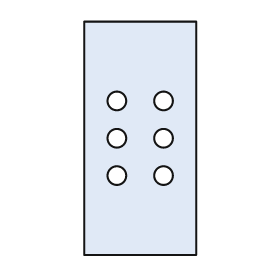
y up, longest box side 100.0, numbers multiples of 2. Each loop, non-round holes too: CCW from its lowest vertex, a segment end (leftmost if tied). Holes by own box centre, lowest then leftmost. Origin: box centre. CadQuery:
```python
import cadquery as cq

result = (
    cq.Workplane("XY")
    .moveTo(-24.0, -50.0)
    .lineTo(24.0, -50.0)
    .lineTo(24.0, 50.0)
    .lineTo(-24.0, 50.0)
    .close()
    .moveTo(-10.0, -16.0)
    .circle(4.0)
    .moveTo(10.0, -16.0)
    .circle(4.0)
    .moveTo(-10.0, 0.0)
    .circle(4.0)
    .moveTo(10.0, 0.0)
    .circle(4.0)
    .moveTo(-10.0, 16.0)
    .circle(4.0)
    .moveTo(10.0, 16.0)
    .circle(4.0)
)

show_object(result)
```